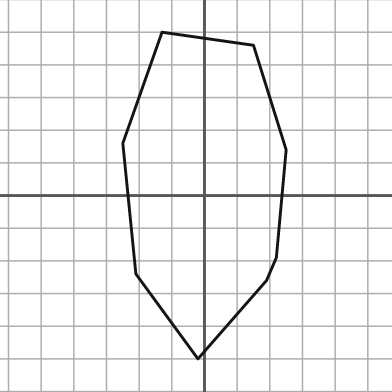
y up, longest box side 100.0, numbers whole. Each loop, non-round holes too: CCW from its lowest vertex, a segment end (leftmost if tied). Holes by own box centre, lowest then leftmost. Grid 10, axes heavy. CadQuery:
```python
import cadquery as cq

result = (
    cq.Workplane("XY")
    .moveTo(-2.0, -50.0)
    .lineTo(19.0, -26.0)
    .lineTo(22.0, -19.0)
    .lineTo(25.0, 14.0)
    .lineTo(15.0, 46.0)
    .lineTo(-13.0, 50.0)
    .lineTo(-25.0, 16.0)
    .lineTo(-21.0, -24.0)
    .close()
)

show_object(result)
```